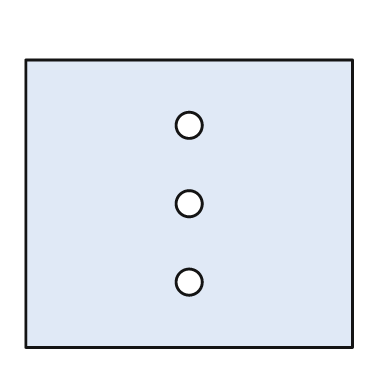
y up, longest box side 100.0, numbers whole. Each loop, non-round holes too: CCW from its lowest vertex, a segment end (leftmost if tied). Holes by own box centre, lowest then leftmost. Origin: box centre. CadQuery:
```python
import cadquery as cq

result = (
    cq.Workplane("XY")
    .moveTo(-50.0, -44.0)
    .lineTo(50.0, -44.0)
    .lineTo(50.0, 44.0)
    .lineTo(-50.0, 44.0)
    .close()
    .moveTo(0.0, -24.0)
    .circle(4.0)
    .moveTo(0.0, 0.0)
    .circle(4.0)
    .moveTo(0.0, 24.0)
    .circle(4.0)
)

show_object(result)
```